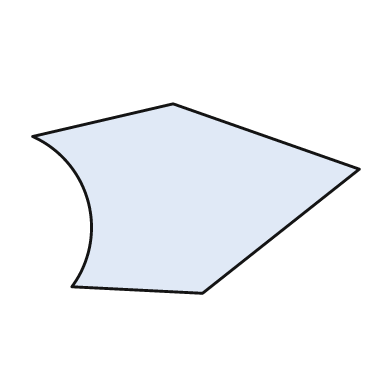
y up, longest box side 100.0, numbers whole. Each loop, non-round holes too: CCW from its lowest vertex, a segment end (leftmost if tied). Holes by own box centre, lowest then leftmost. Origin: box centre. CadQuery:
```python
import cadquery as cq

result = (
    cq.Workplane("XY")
    .moveTo(2.0, -29.0)
    .lineTo(50.0, 9.0)
    .lineTo(-7.0, 29.0)
    .lineTo(-50.0, 19.0)
    .threePointArc((-33.0, -1.0), (-38.0, -27.0))
    .close()
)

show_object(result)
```